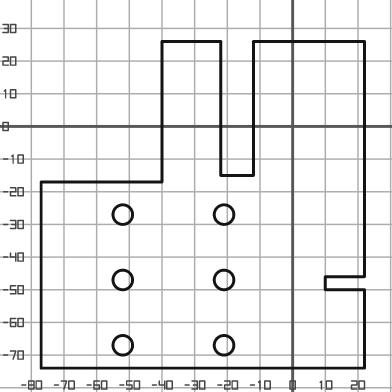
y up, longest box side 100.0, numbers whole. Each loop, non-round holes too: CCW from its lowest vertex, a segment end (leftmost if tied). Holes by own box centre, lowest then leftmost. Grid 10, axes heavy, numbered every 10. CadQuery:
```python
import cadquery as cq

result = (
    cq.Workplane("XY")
    .moveTo(-77.0, -74.0)
    .lineTo(22.0, -74.0)
    .lineTo(22.0, -50.0)
    .lineTo(10.0, -50.0)
    .lineTo(10.0, -46.0)
    .lineTo(22.0, -46.0)
    .lineTo(22.0, 26.0)
    .lineTo(-12.0, 26.0)
    .lineTo(-12.0, -15.0)
    .lineTo(-22.0, -15.0)
    .lineTo(-22.0, 26.0)
    .lineTo(-40.0, 26.0)
    .lineTo(-40.0, -17.0)
    .lineTo(-77.0, -17.0)
    .close()
    .moveTo(-52.0, -67.0)
    .circle(3.0)
    .moveTo(-21.0, -67.0)
    .circle(3.0)
    .moveTo(-52.0, -47.0)
    .circle(3.0)
    .moveTo(-21.0, -47.0)
    .circle(3.0)
    .moveTo(-52.0, -27.0)
    .circle(3.0)
    .moveTo(-21.0, -27.0)
    .circle(3.0)
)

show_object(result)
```